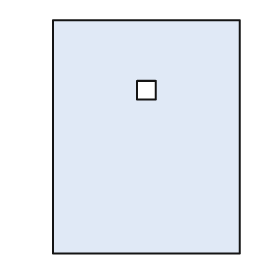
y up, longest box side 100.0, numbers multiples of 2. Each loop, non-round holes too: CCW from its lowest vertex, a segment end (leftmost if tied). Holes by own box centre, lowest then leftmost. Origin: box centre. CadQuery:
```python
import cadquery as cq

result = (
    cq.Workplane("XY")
    .moveTo(-40.0, -50.0)
    .lineTo(40.0, -50.0)
    .lineTo(40.0, 50.0)
    .lineTo(-40.0, 50.0)
    .close()
    .moveTo(-4.0, 16.0)
    .lineTo(4.0, 16.0)
    .lineTo(4.0, 24.0)
    .lineTo(-4.0, 24.0)
    .close()
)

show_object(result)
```